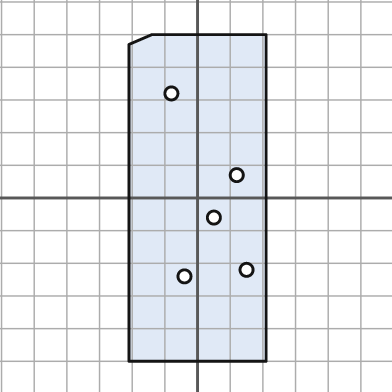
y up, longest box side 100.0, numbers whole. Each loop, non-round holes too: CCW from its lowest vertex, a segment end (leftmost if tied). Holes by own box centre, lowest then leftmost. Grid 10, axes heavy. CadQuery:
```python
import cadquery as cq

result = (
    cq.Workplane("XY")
    .moveTo(-21.0, -50.0)
    .lineTo(21.0, -50.0)
    .lineTo(21.0, 50.0)
    .lineTo(-14.0, 50.0)
    .lineTo(-21.0, 47.0)
    .close()
    .moveTo(-4.0, -24.0)
    .circle(2.0)
    .moveTo(15.0, -22.0)
    .circle(2.0)
    .moveTo(5.0, -6.0)
    .circle(2.0)
    .moveTo(12.0, 7.0)
    .circle(2.0)
    .moveTo(-8.0, 32.0)
    .circle(2.0)
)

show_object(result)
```